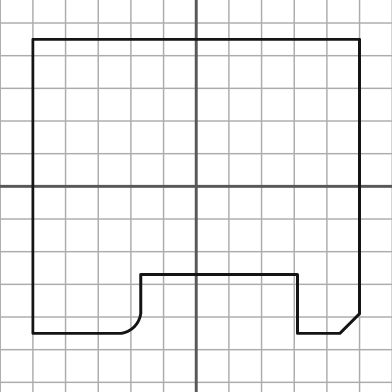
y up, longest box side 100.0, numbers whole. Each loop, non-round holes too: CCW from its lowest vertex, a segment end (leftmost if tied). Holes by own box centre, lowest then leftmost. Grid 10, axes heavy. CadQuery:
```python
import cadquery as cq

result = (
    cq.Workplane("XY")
    .moveTo(-50.0, -45.0)
    .lineTo(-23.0, -45.0)
    .threePointArc((-19.0, -43.0), (-17.0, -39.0))
    .lineTo(-17.0, -27.0)
    .lineTo(31.0, -27.0)
    .lineTo(31.0, -45.0)
    .lineTo(44.0, -45.0)
    .lineTo(50.0, -39.0)
    .lineTo(50.0, 45.0)
    .lineTo(-50.0, 45.0)
    .close()
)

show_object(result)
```